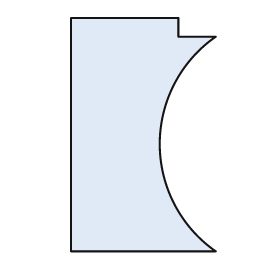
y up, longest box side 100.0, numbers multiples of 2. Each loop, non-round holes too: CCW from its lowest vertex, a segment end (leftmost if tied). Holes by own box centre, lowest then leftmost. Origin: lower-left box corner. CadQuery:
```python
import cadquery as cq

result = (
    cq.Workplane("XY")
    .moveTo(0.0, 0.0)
    .lineTo(62.0, 0.0)
    .threePointArc((38.0, 46.0), (62.0, 92.0))
    .lineTo(46.0, 92.0)
    .lineTo(46.0, 100.0)
    .lineTo(0.0, 100.0)
    .close()
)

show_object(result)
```